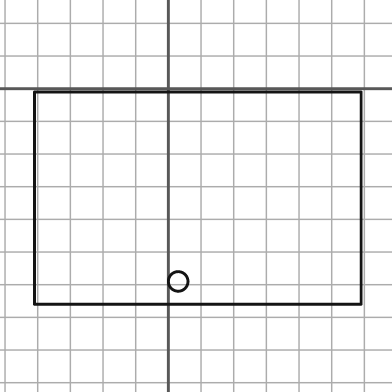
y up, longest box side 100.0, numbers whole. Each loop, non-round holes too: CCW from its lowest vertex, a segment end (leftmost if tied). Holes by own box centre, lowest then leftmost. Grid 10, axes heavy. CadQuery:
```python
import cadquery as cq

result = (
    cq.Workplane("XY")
    .moveTo(-41.0, -66.0)
    .lineTo(59.0, -66.0)
    .lineTo(59.0, -1.0)
    .lineTo(-41.0, -1.0)
    .close()
    .moveTo(3.0, -59.0)
    .circle(3.0)
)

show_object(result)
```